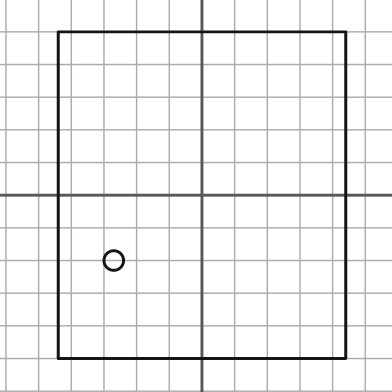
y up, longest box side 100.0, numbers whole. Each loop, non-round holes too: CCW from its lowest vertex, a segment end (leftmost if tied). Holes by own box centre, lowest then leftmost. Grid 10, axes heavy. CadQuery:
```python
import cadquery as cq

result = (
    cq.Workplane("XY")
    .moveTo(-44.0, -50.0)
    .lineTo(44.0, -50.0)
    .lineTo(44.0, 50.0)
    .lineTo(-44.0, 50.0)
    .close()
    .moveTo(-27.0, -20.0)
    .circle(3.0)
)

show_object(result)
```